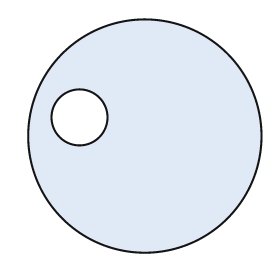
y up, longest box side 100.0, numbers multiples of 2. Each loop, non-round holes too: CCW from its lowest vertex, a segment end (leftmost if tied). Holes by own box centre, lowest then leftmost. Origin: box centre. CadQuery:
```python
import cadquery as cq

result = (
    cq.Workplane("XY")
    .moveTo(0.0, 0.0)
    .circle(50.0)
    .moveTo(-28.0, 8.0)
    .circle(12.0)
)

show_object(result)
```